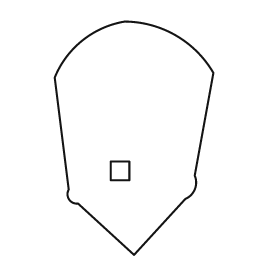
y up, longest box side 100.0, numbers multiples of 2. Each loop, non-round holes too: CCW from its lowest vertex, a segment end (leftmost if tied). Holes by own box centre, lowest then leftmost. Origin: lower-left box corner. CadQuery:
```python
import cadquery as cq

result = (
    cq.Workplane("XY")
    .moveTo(34.0, 0.0)
    .lineTo(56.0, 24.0)
    .threePointArc((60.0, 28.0), (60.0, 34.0))
    .lineTo(68.0, 78.0)
    .threePointArc((52.0, 94.0), (30.0, 100.0))
    .threePointArc((12.0, 92.0), (0.0, 76.0))
    .lineTo(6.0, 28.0)
    .threePointArc((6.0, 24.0), (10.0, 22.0))
    .close()
    .moveTo(24.0, 32.0)
    .lineTo(32.0, 32.0)
    .lineTo(32.0, 40.0)
    .lineTo(24.0, 40.0)
    .close()
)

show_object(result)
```